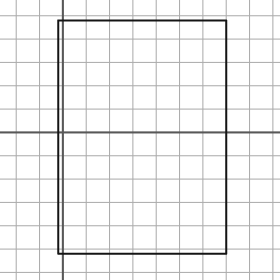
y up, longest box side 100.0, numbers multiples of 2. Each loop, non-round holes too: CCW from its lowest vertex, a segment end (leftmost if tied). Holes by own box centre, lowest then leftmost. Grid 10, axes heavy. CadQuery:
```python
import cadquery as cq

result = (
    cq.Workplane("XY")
    .moveTo(-2.0, -52.0)
    .lineTo(70.0, -52.0)
    .lineTo(70.0, 48.0)
    .lineTo(-2.0, 48.0)
    .close()
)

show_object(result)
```